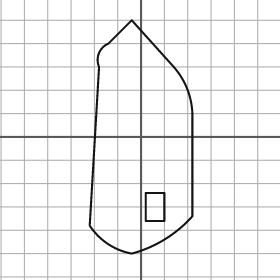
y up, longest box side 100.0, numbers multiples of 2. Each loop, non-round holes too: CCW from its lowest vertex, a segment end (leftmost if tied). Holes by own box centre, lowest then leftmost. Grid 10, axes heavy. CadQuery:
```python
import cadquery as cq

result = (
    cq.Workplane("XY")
    .moveTo(-4.0, -50.0)
    .threePointArc((10.0, -44.0), (22.0, -34.0))
    .lineTo(22.0, 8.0)
    .threePointArc((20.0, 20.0), (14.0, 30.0))
    .lineTo(-4.0, 50.0)
    .lineTo(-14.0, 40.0)
    .threePointArc((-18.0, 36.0), (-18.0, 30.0))
    .lineTo(-22.0, -38.0)
    .threePointArc((-14.0, -46.0), (-4.0, -50.0))
    .close()
    .moveTo(2.0, -36.0)
    .lineTo(10.0, -36.0)
    .lineTo(10.0, -24.0)
    .lineTo(2.0, -24.0)
    .close()
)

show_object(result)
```